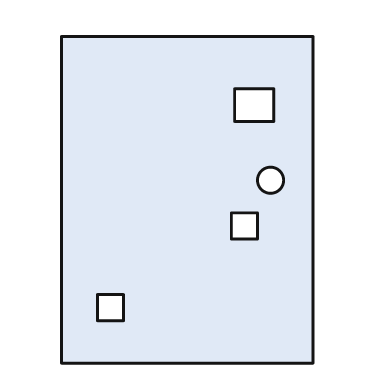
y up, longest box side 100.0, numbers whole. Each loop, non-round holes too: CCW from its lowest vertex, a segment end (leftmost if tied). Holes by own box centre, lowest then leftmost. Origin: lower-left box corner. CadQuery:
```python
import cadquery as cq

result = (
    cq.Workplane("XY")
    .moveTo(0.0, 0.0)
    .lineTo(77.0, 0.0)
    .lineTo(77.0, 100.0)
    .lineTo(0.0, 100.0)
    .close()
    .moveTo(11.0, 13.0)
    .lineTo(19.0, 13.0)
    .lineTo(19.0, 21.0)
    .lineTo(11.0, 21.0)
    .close()
    .moveTo(52.0, 38.0)
    .lineTo(60.0, 38.0)
    .lineTo(60.0, 46.0)
    .lineTo(52.0, 46.0)
    .close()
    .moveTo(64.0, 56.0)
    .circle(4.0)
    .moveTo(53.0, 74.0)
    .lineTo(65.0, 74.0)
    .lineTo(65.0, 84.0)
    .lineTo(53.0, 84.0)
    .close()
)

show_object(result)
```